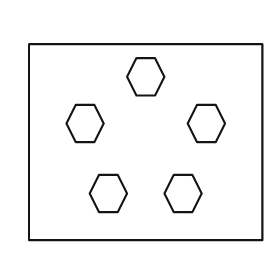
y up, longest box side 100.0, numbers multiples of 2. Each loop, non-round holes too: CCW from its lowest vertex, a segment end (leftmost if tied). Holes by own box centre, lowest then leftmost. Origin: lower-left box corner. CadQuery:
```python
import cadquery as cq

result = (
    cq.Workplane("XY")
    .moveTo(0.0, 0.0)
    .lineTo(100.0, 0.0)
    .lineTo(100.0, 84.0)
    .lineTo(0.0, 84.0)
    .close()
    .moveTo(30.0, 12.0)
    .lineTo(38.0, 12.0)
    .lineTo(42.0, 20.0)
    .lineTo(38.0, 28.0)
    .lineTo(30.0, 28.0)
    .lineTo(26.0, 20.0)
    .close()
    .moveTo(62.0, 12.0)
    .lineTo(70.0, 12.0)
    .lineTo(74.0, 20.0)
    .lineTo(70.0, 28.0)
    .lineTo(62.0, 28.0)
    .lineTo(58.0, 20.0)
    .close()
    .moveTo(20.0, 42.0)
    .lineTo(28.0, 42.0)
    .lineTo(32.0, 50.0)
    .lineTo(28.0, 58.0)
    .lineTo(20.0, 58.0)
    .lineTo(16.0, 50.0)
    .close()
    .moveTo(72.0, 42.0)
    .lineTo(80.0, 42.0)
    .lineTo(84.0, 50.0)
    .lineTo(80.0, 58.0)
    .lineTo(72.0, 58.0)
    .lineTo(68.0, 50.0)
    .close()
    .moveTo(46.0, 62.0)
    .lineTo(54.0, 62.0)
    .lineTo(58.0, 70.0)
    .lineTo(54.0, 78.0)
    .lineTo(46.0, 78.0)
    .lineTo(42.0, 70.0)
    .close()
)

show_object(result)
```